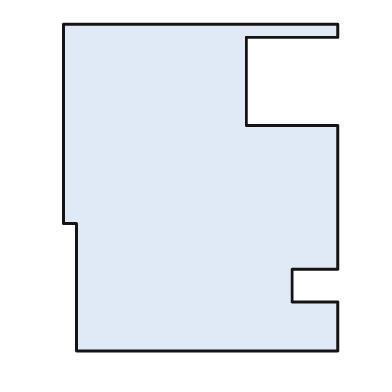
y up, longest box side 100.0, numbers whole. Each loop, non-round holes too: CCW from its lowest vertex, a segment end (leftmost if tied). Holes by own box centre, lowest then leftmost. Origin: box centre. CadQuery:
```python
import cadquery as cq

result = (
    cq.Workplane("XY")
    .moveTo(-38.0, -50.0)
    .lineTo(42.0, -50.0)
    .lineTo(42.0, -35.0)
    .lineTo(28.0, -35.0)
    .lineTo(28.0, -25.0)
    .lineTo(42.0, -25.0)
    .lineTo(42.0, 19.0)
    .lineTo(14.0, 19.0)
    .lineTo(14.0, 46.0)
    .lineTo(42.0, 46.0)
    .lineTo(42.0, 50.0)
    .lineTo(-42.0, 50.0)
    .lineTo(-42.0, -11.0)
    .lineTo(-38.0, -11.0)
    .close()
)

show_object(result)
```